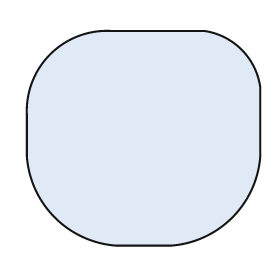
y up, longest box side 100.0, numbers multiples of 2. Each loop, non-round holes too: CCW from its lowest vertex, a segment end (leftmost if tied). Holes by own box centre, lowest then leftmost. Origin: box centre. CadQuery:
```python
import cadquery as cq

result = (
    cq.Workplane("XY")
    .moveTo(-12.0, -46.0)
    .lineTo(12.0, -46.0)
    .threePointArc((38.0, -34.0), (50.0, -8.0))
    .lineTo(50.0, 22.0)
    .threePointArc((42.0, 38.0), (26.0, 46.0))
    .lineTo(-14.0, 46.0)
    .threePointArc((-40.0, 36.0), (-50.0, 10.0))
    .lineTo(-50.0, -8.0)
    .threePointArc((-38.0, -34.0), (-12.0, -46.0))
    .close()
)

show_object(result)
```